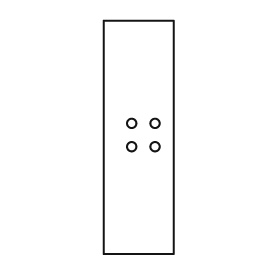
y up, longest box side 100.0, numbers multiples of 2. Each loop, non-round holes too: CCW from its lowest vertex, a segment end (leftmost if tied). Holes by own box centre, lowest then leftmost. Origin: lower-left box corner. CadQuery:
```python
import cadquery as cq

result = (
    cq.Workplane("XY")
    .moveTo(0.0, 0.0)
    .lineTo(30.0, 0.0)
    .lineTo(30.0, 100.0)
    .lineTo(0.0, 100.0)
    .close()
    .moveTo(12.0, 46.0)
    .circle(2.0)
    .moveTo(22.0, 46.0)
    .circle(2.0)
    .moveTo(12.0, 56.0)
    .circle(2.0)
    .moveTo(22.0, 56.0)
    .circle(2.0)
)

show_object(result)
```